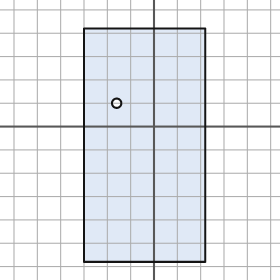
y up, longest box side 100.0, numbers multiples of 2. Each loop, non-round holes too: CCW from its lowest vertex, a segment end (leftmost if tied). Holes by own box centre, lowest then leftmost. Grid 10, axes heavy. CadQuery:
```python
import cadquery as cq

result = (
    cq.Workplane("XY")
    .moveTo(-30.0, -58.0)
    .lineTo(22.0, -58.0)
    .lineTo(22.0, 42.0)
    .lineTo(-30.0, 42.0)
    .close()
    .moveTo(-16.0, 10.0)
    .circle(2.0)
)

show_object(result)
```